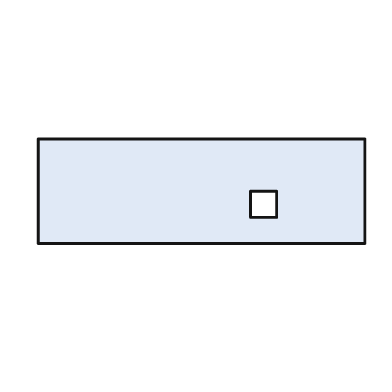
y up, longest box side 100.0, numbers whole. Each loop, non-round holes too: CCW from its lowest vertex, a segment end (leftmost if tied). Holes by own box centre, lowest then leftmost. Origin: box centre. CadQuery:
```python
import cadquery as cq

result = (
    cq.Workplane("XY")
    .moveTo(-50.0, -16.0)
    .lineTo(50.0, -16.0)
    .lineTo(50.0, 16.0)
    .lineTo(-50.0, 16.0)
    .close()
    .moveTo(15.0, -8.0)
    .lineTo(23.0, -8.0)
    .lineTo(23.0, 0.0)
    .lineTo(15.0, 0.0)
    .close()
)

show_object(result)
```